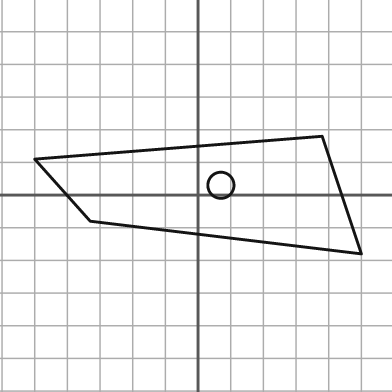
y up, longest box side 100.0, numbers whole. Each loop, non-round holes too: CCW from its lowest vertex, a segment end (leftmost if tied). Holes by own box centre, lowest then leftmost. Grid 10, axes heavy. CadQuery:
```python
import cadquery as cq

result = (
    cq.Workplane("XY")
    .moveTo(50.0, -18.0)
    .lineTo(38.0, 18.0)
    .lineTo(-50.0, 11.0)
    .lineTo(-33.0, -8.0)
    .close()
    .moveTo(7.0, 3.0)
    .circle(4.0)
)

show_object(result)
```